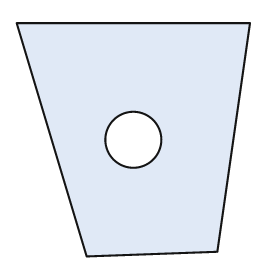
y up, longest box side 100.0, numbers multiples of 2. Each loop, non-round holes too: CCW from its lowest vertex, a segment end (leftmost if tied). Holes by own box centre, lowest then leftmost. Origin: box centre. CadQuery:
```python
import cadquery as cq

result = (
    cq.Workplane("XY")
    .moveTo(-20.0, -50.0)
    .lineTo(36.0, -48.0)
    .lineTo(50.0, 50.0)
    .lineTo(-50.0, 50.0)
    .close()
    .moveTo(0.0, 0.0)
    .circle(12.0)
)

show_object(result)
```